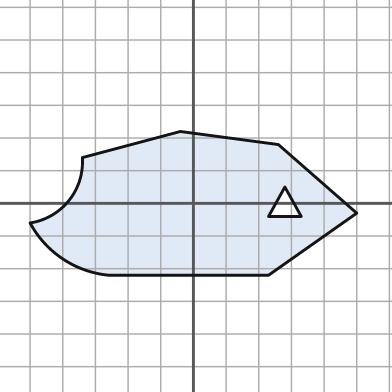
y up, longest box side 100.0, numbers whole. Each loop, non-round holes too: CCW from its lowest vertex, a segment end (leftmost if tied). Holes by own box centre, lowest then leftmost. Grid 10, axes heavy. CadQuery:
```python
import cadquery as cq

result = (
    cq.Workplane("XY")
    .moveTo(-26.0, -22.0)
    .lineTo(23.0, -22.0)
    .lineTo(50.0, -3.0)
    .lineTo(26.0, 18.0)
    .lineTo(-4.0, 22.0)
    .lineTo(-34.0, 14.0)
    .threePointArc((-38.0, 1.0), (-50.0, -6.0))
    .threePointArc((-40.0, -17.0), (-26.0, -22.0))
    .close()
    .moveTo(23.0, -4.0)
    .lineTo(33.0, -4.0)
    .lineTo(28.0, 5.0)
    .close()
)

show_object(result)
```